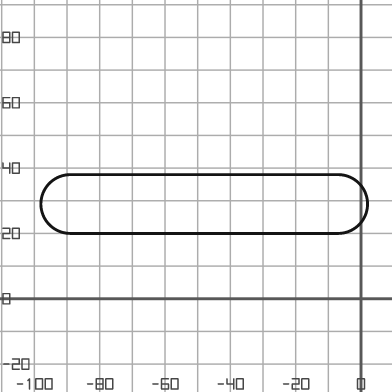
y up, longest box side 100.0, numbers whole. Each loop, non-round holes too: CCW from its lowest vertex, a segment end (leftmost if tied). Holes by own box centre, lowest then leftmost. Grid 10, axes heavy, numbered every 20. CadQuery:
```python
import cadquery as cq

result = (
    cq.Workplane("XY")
    .moveTo(-89.0, 20.0)
    .lineTo(-7.0, 20.0)
    .threePointArc((2.0, 29.0), (-7.0, 38.0))
    .lineTo(-89.0, 38.0)
    .threePointArc((-98.0, 29.0), (-89.0, 20.0))
    .close()
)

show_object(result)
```